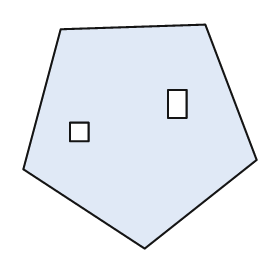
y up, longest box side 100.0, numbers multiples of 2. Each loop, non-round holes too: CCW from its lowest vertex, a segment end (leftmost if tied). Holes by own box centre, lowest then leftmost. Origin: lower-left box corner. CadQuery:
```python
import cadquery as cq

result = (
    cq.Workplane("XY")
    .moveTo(52.0, 0.0)
    .lineTo(100.0, 38.0)
    .lineTo(78.0, 96.0)
    .lineTo(16.0, 94.0)
    .lineTo(0.0, 34.0)
    .close()
    .moveTo(20.0, 46.0)
    .lineTo(28.0, 46.0)
    .lineTo(28.0, 54.0)
    .lineTo(20.0, 54.0)
    .close()
    .moveTo(62.0, 56.0)
    .lineTo(70.0, 56.0)
    .lineTo(70.0, 68.0)
    .lineTo(62.0, 68.0)
    .close()
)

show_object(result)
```